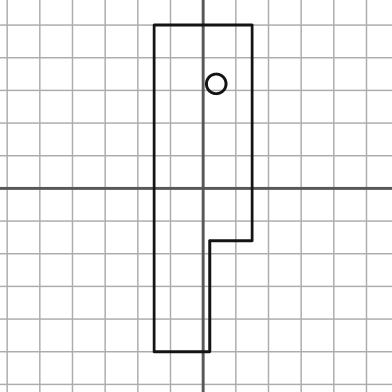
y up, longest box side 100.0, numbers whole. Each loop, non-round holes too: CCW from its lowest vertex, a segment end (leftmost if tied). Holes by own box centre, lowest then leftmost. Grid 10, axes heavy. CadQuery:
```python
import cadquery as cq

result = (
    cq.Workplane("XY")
    .moveTo(-15.0, -50.0)
    .lineTo(2.0, -50.0)
    .lineTo(2.0, -16.0)
    .lineTo(15.0, -16.0)
    .lineTo(15.0, 50.0)
    .lineTo(-15.0, 50.0)
    .close()
    .moveTo(4.0, 32.0)
    .circle(3.0)
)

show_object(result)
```